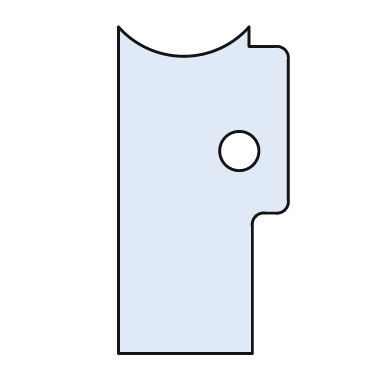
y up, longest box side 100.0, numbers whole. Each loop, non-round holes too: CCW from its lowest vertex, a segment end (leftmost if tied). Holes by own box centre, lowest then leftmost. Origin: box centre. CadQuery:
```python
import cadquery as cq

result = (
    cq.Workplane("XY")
    .moveTo(-26.0, -50.0)
    .lineTo(15.0, -50.0)
    .lineTo(15.0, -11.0)
    .threePointArc((16.0, -8.0), (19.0, -7.0))
    .lineTo(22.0, -7.0)
    .threePointArc((25.0, -6.0), (26.0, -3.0))
    .lineTo(26.0, 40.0)
    .threePointArc((25.0, 43.0), (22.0, 44.0))
    .lineTo(14.0, 44.0)
    .lineTo(14.0, 50.0)
    .threePointArc((-6.0, 41.0), (-26.0, 50.0))
    .close()
    .moveTo(11.0, 12.0)
    .circle(6.0)
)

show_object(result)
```